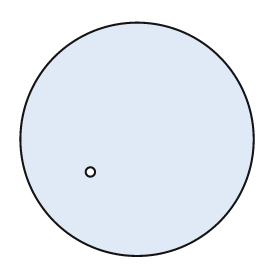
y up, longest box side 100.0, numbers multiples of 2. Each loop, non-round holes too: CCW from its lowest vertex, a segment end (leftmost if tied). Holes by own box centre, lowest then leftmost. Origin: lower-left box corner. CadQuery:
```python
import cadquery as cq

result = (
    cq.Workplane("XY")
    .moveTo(50.0, 50.0)
    .circle(50.0)
    .moveTo(30.0, 36.0)
    .circle(2.0)
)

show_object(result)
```